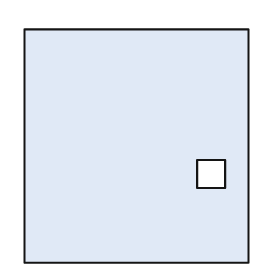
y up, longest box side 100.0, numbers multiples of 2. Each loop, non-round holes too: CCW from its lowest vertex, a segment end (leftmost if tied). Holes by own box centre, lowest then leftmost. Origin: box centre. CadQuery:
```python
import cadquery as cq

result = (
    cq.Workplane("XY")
    .moveTo(-48.0, -50.0)
    .lineTo(48.0, -50.0)
    .lineTo(48.0, 50.0)
    .lineTo(-48.0, 50.0)
    .close()
    .moveTo(26.0, -18.0)
    .lineTo(38.0, -18.0)
    .lineTo(38.0, -6.0)
    .lineTo(26.0, -6.0)
    .close()
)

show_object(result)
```